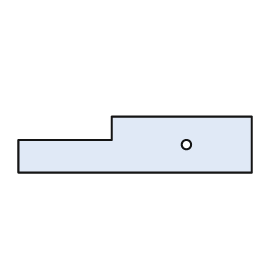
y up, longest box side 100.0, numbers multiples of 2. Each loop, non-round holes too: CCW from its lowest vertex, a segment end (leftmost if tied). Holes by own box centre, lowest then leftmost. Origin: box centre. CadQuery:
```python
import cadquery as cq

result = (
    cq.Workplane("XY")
    .moveTo(-50.0, -12.0)
    .lineTo(50.0, -12.0)
    .lineTo(50.0, 12.0)
    .lineTo(-10.0, 12.0)
    .lineTo(-10.0, 2.0)
    .lineTo(-50.0, 2.0)
    .close()
    .moveTo(22.0, 0.0)
    .circle(2.0)
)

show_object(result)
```